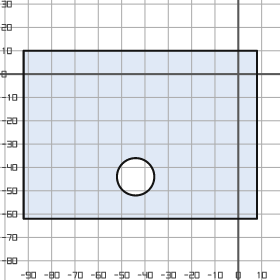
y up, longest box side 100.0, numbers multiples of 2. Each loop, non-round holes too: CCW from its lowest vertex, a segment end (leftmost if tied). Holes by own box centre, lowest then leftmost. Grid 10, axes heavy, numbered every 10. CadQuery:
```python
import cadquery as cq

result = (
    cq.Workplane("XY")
    .moveTo(-92.0, -62.0)
    .lineTo(8.0, -62.0)
    .lineTo(8.0, 10.0)
    .lineTo(-92.0, 10.0)
    .close()
    .moveTo(-44.0, -44.0)
    .circle(8.0)
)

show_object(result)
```